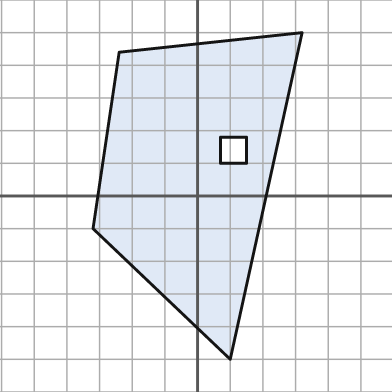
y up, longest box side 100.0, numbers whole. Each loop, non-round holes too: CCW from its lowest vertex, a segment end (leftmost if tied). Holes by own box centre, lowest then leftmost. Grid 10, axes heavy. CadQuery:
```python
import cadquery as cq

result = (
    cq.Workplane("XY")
    .moveTo(10.0, -50.0)
    .lineTo(32.0, 50.0)
    .lineTo(-24.0, 44.0)
    .lineTo(-32.0, -10.0)
    .close()
    .moveTo(7.0, 10.0)
    .lineTo(15.0, 10.0)
    .lineTo(15.0, 18.0)
    .lineTo(7.0, 18.0)
    .close()
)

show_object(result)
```